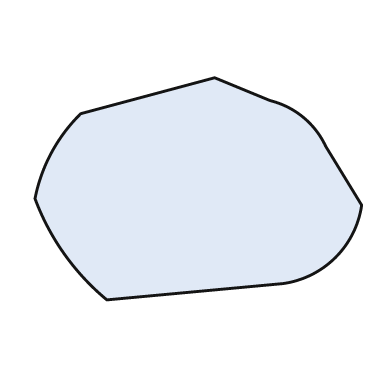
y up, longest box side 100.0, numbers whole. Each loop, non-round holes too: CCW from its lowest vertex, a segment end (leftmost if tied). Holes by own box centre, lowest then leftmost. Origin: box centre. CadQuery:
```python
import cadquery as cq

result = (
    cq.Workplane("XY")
    .moveTo(-28.0, -34.0)
    .lineTo(26.0, -29.0)
    .threePointArc((42.0, -21.0), (50.0, -5.0))
    .lineTo(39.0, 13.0)
    .threePointArc((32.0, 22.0), (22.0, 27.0))
    .lineTo(5.0, 34.0)
    .lineTo(-36.0, 23.0)
    .threePointArc((-45.0, 11.0), (-50.0, -3.0))
    .threePointArc((-41.0, -20.0), (-28.0, -34.0))
    .close()
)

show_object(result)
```